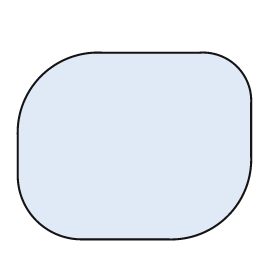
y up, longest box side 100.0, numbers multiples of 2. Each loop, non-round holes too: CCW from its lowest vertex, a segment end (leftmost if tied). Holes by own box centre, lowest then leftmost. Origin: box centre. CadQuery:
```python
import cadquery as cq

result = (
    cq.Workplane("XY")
    .moveTo(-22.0, -40.0)
    .lineTo(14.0, -40.0)
    .threePointArc((40.0, -30.0), (50.0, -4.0))
    .lineTo(50.0, 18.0)
    .threePointArc((44.0, 34.0), (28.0, 40.0))
    .lineTo(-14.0, 40.0)
    .threePointArc((-40.0, 30.0), (-50.0, 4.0))
    .lineTo(-50.0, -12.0)
    .threePointArc((-42.0, -32.0), (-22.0, -40.0))
    .close()
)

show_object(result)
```